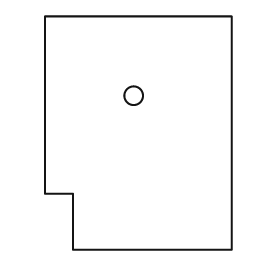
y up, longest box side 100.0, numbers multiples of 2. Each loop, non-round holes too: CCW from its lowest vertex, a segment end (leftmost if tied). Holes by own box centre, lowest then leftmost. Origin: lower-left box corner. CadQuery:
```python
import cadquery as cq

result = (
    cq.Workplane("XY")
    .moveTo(12.0, 0.0)
    .lineTo(80.0, 0.0)
    .lineTo(80.0, 100.0)
    .lineTo(0.0, 100.0)
    .lineTo(0.0, 24.0)
    .lineTo(12.0, 24.0)
    .close()
    .moveTo(38.0, 66.0)
    .circle(4.0)
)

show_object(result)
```